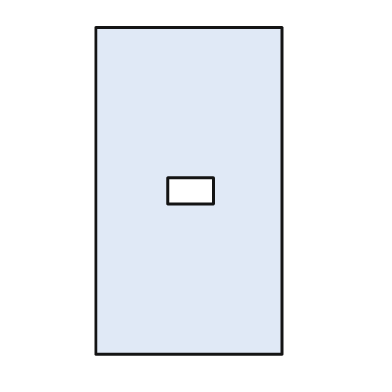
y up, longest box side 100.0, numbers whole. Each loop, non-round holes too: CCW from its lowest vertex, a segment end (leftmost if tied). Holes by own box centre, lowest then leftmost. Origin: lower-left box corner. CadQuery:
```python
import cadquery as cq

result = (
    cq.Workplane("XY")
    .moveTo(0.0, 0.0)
    .lineTo(57.0, 0.0)
    .lineTo(57.0, 100.0)
    .lineTo(0.0, 100.0)
    .close()
    .moveTo(22.0, 46.0)
    .lineTo(36.0, 46.0)
    .lineTo(36.0, 54.0)
    .lineTo(22.0, 54.0)
    .close()
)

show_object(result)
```